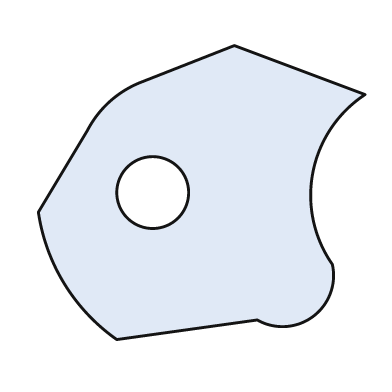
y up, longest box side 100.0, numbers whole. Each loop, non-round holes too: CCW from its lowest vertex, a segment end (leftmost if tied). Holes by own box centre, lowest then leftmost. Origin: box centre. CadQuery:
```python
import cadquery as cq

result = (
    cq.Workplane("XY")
    .moveTo(-26.0, -45.0)
    .lineTo(17.0, -39.0)
    .threePointArc((34.0, -38.0), (40.0, -22.0))
    .threePointArc((34.0, 6.0), (50.0, 30.0))
    .lineTo(10.0, 45.0)
    .lineTo(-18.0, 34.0)
    .threePointArc((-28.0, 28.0), (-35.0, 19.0))
    .lineTo(-50.0, -6.0)
    .threePointArc((-42.0, -28.0), (-26.0, -45.0))
    .close()
    .moveTo(-15.0, 0.0)
    .circle(11.0)
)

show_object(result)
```